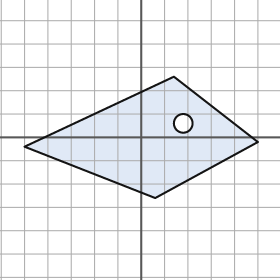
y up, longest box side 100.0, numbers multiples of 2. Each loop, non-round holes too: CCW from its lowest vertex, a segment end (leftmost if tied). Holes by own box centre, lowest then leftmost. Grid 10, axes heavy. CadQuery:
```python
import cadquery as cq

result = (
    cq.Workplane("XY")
    .moveTo(6.0, -26.0)
    .lineTo(50.0, -2.0)
    .lineTo(14.0, 26.0)
    .lineTo(-50.0, -4.0)
    .close()
    .moveTo(18.0, 6.0)
    .circle(4.0)
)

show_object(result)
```